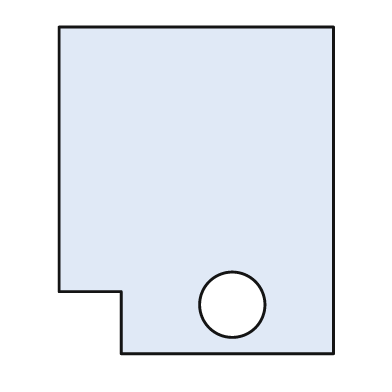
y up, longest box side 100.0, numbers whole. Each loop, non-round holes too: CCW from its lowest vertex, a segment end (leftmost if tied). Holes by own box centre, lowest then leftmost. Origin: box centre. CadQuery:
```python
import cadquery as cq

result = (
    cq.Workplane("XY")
    .moveTo(-23.0, -50.0)
    .lineTo(42.0, -50.0)
    .lineTo(42.0, 50.0)
    .lineTo(-42.0, 50.0)
    .lineTo(-42.0, -31.0)
    .lineTo(-23.0, -31.0)
    .close()
    .moveTo(11.0, -35.0)
    .circle(10.0)
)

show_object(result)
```